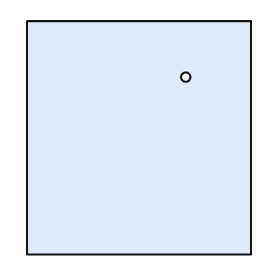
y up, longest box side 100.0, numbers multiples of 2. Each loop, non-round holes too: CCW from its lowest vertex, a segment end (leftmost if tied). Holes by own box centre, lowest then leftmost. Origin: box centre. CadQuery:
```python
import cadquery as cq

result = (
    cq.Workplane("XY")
    .moveTo(-48.0, -50.0)
    .lineTo(48.0, -50.0)
    .lineTo(48.0, 50.0)
    .lineTo(-48.0, 50.0)
    .close()
    .moveTo(20.0, 26.0)
    .circle(2.0)
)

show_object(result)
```